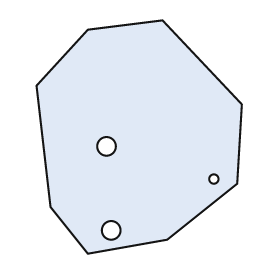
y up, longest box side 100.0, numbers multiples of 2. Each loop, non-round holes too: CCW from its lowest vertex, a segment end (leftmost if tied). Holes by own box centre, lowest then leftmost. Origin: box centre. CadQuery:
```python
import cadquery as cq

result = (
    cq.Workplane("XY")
    .moveTo(-22.0, -50.0)
    .lineTo(12.0, -44.0)
    .lineTo(42.0, -20.0)
    .lineTo(44.0, 14.0)
    .lineTo(10.0, 50.0)
    .lineTo(-22.0, 46.0)
    .lineTo(-44.0, 22.0)
    .lineTo(-38.0, -30.0)
    .close()
    .moveTo(-12.0, -40.0)
    .circle(4.0)
    .moveTo(32.0, -18.0)
    .circle(2.0)
    .moveTo(-14.0, -4.0)
    .circle(4.0)
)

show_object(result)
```